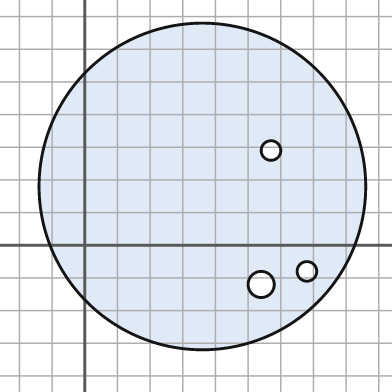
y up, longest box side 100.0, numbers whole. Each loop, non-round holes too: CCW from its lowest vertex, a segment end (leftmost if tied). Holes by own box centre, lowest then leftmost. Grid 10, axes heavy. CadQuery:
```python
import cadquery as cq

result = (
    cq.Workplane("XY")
    .moveTo(36.0, 18.0)
    .circle(50.0)
    .moveTo(54.0, -12.0)
    .circle(4.0)
    .moveTo(68.0, -8.0)
    .circle(3.0)
    .moveTo(57.0, 29.0)
    .circle(3.0)
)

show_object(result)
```